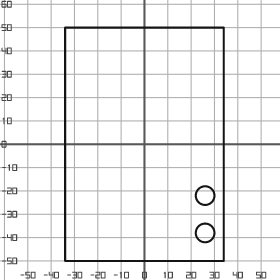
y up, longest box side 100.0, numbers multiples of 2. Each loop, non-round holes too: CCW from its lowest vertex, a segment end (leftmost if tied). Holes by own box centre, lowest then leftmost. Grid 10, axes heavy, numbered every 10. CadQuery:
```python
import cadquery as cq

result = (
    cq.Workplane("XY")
    .moveTo(-34.0, -50.0)
    .lineTo(34.0, -50.0)
    .lineTo(34.0, 50.0)
    .lineTo(-34.0, 50.0)
    .close()
    .moveTo(26.0, -38.0)
    .circle(4.0)
    .moveTo(26.0, -22.0)
    .circle(4.0)
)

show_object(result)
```